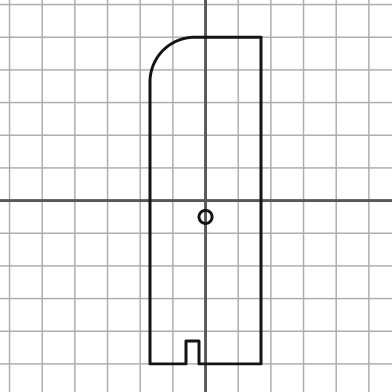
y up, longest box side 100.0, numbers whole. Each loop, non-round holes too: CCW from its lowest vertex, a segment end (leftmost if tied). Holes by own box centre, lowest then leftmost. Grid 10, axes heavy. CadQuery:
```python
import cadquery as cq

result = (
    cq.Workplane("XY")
    .moveTo(-17.0, -50.0)
    .lineTo(-6.0, -50.0)
    .lineTo(-6.0, -43.0)
    .lineTo(-2.0, -43.0)
    .lineTo(-2.0, -50.0)
    .lineTo(17.0, -50.0)
    .lineTo(17.0, 50.0)
    .lineTo(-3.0, 50.0)
    .threePointArc((-13.0, 46.0), (-17.0, 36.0))
    .close()
    .moveTo(0.0, -5.0)
    .circle(2.0)
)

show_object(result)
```